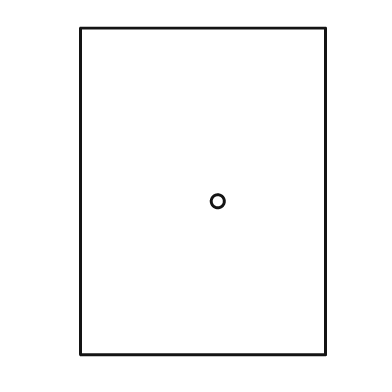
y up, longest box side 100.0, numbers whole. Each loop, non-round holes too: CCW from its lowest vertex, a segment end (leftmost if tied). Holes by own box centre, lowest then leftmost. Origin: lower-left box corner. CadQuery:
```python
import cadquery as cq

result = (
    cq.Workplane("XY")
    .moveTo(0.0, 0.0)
    .lineTo(75.0, 0.0)
    .lineTo(75.0, 100.0)
    .lineTo(0.0, 100.0)
    .close()
    .moveTo(42.0, 47.0)
    .circle(2.0)
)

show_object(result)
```